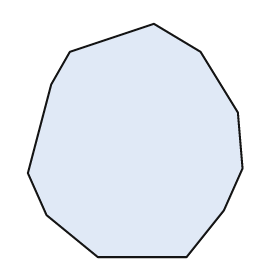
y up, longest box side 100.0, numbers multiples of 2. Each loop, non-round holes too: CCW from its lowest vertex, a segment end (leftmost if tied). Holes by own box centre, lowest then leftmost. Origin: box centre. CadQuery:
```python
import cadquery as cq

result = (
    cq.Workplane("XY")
    .moveTo(-16.0, -50.0)
    .lineTo(22.0, -50.0)
    .lineTo(38.0, -30.0)
    .lineTo(46.0, -12.0)
    .lineTo(44.0, 12.0)
    .lineTo(28.0, 38.0)
    .lineTo(8.0, 50.0)
    .lineTo(-28.0, 38.0)
    .lineTo(-36.0, 24.0)
    .lineTo(-46.0, -14.0)
    .lineTo(-38.0, -32.0)
    .close()
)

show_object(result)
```